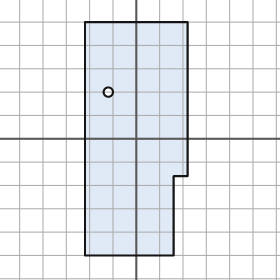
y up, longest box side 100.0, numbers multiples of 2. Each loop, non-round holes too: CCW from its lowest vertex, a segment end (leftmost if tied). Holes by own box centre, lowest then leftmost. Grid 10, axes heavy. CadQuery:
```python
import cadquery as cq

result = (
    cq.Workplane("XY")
    .moveTo(-22.0, -50.0)
    .lineTo(16.0, -50.0)
    .lineTo(16.0, -16.0)
    .lineTo(22.0, -16.0)
    .lineTo(22.0, 50.0)
    .lineTo(-22.0, 50.0)
    .close()
    .moveTo(-12.0, 20.0)
    .circle(2.0)
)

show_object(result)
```